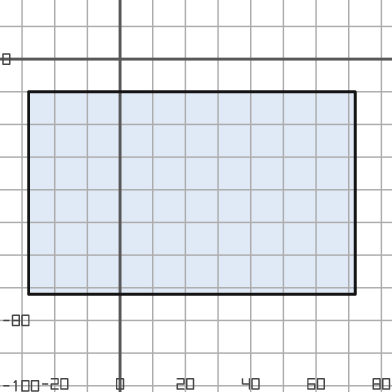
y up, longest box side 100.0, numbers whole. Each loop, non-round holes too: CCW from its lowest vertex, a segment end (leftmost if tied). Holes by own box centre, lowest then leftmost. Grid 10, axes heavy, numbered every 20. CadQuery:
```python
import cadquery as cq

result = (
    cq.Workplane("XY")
    .moveTo(-28.0, -72.0)
    .lineTo(72.0, -72.0)
    .lineTo(72.0, -10.0)
    .lineTo(-28.0, -10.0)
    .close()
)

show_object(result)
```